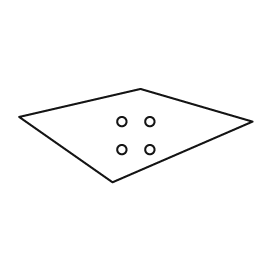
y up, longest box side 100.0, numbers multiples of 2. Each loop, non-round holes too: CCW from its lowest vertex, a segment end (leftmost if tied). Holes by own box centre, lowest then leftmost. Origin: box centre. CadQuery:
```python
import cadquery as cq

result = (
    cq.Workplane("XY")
    .moveTo(-10.0, -20.0)
    .lineTo(50.0, 6.0)
    .lineTo(2.0, 20.0)
    .lineTo(-50.0, 8.0)
    .close()
    .moveTo(-6.0, -6.0)
    .circle(2.0)
    .moveTo(6.0, -6.0)
    .circle(2.0)
    .moveTo(-6.0, 6.0)
    .circle(2.0)
    .moveTo(6.0, 6.0)
    .circle(2.0)
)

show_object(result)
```